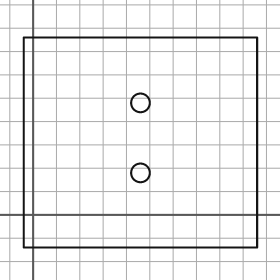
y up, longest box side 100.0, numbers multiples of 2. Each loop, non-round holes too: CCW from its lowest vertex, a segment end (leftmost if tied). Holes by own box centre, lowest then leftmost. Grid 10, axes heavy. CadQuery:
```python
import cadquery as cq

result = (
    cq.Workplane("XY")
    .moveTo(-4.0, -14.0)
    .lineTo(96.0, -14.0)
    .lineTo(96.0, 76.0)
    .lineTo(-4.0, 76.0)
    .close()
    .moveTo(46.0, 18.0)
    .circle(4.0)
    .moveTo(46.0, 48.0)
    .circle(4.0)
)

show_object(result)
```